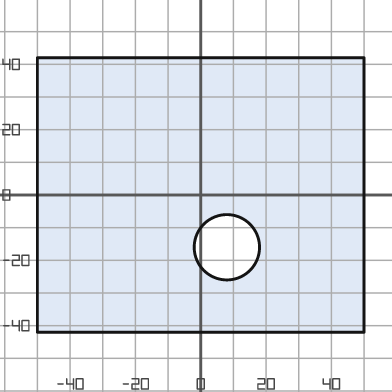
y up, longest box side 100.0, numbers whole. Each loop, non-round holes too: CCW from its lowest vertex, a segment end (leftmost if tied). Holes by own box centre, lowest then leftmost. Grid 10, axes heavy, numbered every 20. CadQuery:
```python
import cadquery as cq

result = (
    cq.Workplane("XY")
    .moveTo(-50.0, -42.0)
    .lineTo(50.0, -42.0)
    .lineTo(50.0, 42.0)
    .lineTo(-50.0, 42.0)
    .close()
    .moveTo(8.0, -16.0)
    .circle(10.0)
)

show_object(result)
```